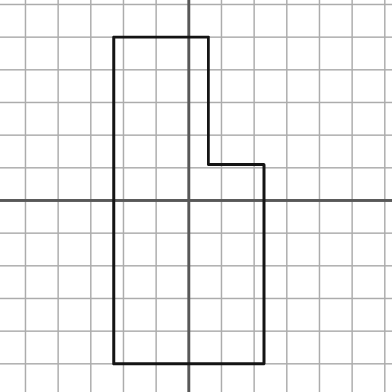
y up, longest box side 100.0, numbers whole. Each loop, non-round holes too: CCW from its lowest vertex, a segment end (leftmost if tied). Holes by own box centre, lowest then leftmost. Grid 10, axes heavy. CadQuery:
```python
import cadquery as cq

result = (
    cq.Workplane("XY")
    .moveTo(-23.0, -50.0)
    .lineTo(23.0, -50.0)
    .lineTo(23.0, 11.0)
    .lineTo(6.0, 11.0)
    .lineTo(6.0, 50.0)
    .lineTo(-23.0, 50.0)
    .close()
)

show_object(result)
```